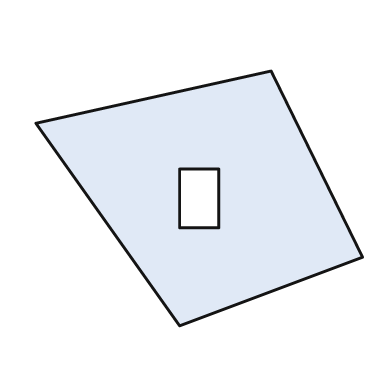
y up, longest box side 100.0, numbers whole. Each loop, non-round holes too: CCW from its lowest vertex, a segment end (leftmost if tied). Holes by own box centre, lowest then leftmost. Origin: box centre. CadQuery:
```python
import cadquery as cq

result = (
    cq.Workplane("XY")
    .moveTo(-6.0, -39.0)
    .lineTo(50.0, -18.0)
    .lineTo(22.0, 39.0)
    .lineTo(-50.0, 23.0)
    .close()
    .moveTo(-6.0, -9.0)
    .lineTo(6.0, -9.0)
    .lineTo(6.0, 9.0)
    .lineTo(-6.0, 9.0)
    .close()
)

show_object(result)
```